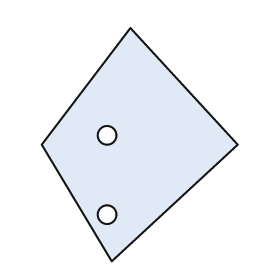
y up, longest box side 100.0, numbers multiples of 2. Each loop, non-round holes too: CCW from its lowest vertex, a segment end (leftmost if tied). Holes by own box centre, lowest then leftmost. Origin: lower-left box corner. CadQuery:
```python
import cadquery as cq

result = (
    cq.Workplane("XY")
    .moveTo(30.0, 0.0)
    .lineTo(84.0, 50.0)
    .lineTo(38.0, 100.0)
    .lineTo(0.0, 50.0)
    .close()
    .moveTo(28.0, 20.0)
    .circle(4.0)
    .moveTo(28.0, 54.0)
    .circle(4.0)
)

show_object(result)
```